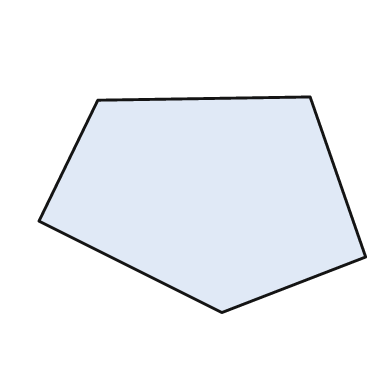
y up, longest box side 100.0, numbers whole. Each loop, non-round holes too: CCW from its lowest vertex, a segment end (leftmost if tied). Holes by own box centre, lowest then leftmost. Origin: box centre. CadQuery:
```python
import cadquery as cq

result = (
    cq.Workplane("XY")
    .moveTo(6.0, -33.0)
    .lineTo(50.0, -16.0)
    .lineTo(33.0, 33.0)
    .lineTo(-32.0, 32.0)
    .lineTo(-50.0, -5.0)
    .close()
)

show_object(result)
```